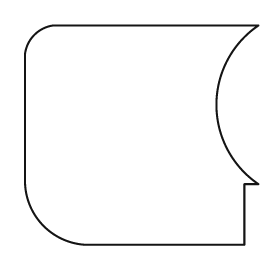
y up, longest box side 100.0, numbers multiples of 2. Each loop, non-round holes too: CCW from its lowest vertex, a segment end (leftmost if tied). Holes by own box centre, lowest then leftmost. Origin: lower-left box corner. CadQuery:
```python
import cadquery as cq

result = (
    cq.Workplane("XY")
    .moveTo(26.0, 0.0)
    .lineTo(94.0, 0.0)
    .lineTo(94.0, 26.0)
    .lineTo(100.0, 26.0)
    .threePointArc((82.0, 60.0), (100.0, 94.0))
    .lineTo(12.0, 94.0)
    .threePointArc((4.0, 90.0), (0.0, 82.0))
    .lineTo(0.0, 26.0)
    .threePointArc((8.0, 8.0), (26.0, 0.0))
    .close()
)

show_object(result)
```